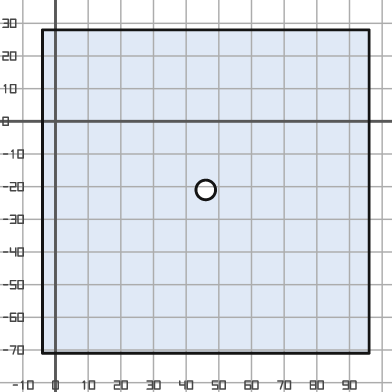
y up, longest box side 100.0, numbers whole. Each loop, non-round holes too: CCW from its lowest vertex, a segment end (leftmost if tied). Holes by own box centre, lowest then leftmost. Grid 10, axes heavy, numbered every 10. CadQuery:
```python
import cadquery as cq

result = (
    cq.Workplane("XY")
    .moveTo(-4.0, -71.0)
    .lineTo(96.0, -71.0)
    .lineTo(96.0, 28.0)
    .lineTo(-4.0, 28.0)
    .close()
    .moveTo(46.0, -21.0)
    .circle(3.0)
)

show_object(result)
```